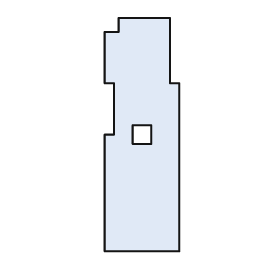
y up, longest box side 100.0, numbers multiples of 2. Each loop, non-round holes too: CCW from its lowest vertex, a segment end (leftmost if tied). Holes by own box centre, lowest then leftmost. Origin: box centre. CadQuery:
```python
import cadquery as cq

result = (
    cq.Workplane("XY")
    .moveTo(-16.0, -50.0)
    .lineTo(16.0, -50.0)
    .lineTo(16.0, 22.0)
    .lineTo(12.0, 22.0)
    .lineTo(12.0, 50.0)
    .lineTo(-10.0, 50.0)
    .lineTo(-10.0, 44.0)
    .lineTo(-16.0, 44.0)
    .lineTo(-16.0, 22.0)
    .lineTo(-12.0, 22.0)
    .lineTo(-12.0, 0.0)
    .lineTo(-16.0, 0.0)
    .close()
    .moveTo(-4.0, -4.0)
    .lineTo(4.0, -4.0)
    .lineTo(4.0, 4.0)
    .lineTo(-4.0, 4.0)
    .close()
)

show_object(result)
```